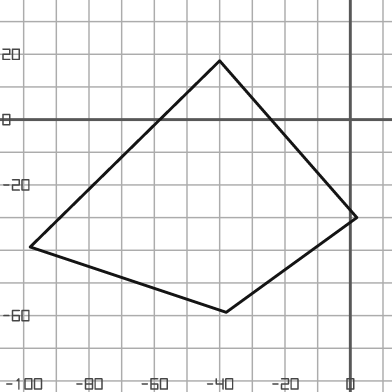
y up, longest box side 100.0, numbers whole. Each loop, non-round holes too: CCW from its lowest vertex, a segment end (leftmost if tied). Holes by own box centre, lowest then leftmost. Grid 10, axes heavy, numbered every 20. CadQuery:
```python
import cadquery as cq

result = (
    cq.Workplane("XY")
    .moveTo(-38.0, -59.0)
    .lineTo(2.0, -30.0)
    .lineTo(-40.0, 18.0)
    .lineTo(-98.0, -39.0)
    .close()
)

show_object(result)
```